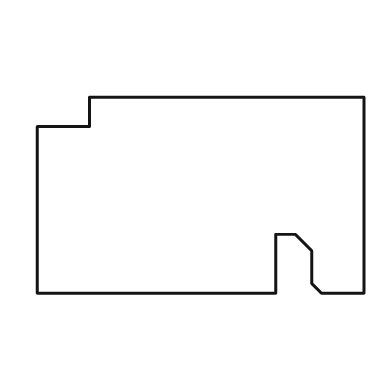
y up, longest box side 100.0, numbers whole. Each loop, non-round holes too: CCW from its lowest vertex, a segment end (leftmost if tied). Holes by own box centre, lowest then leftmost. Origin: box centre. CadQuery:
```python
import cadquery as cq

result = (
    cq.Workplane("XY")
    .moveTo(-50.0, -30.0)
    .lineTo(23.0, -30.0)
    .lineTo(23.0, -12.0)
    .lineTo(29.0, -12.0)
    .lineTo(34.0, -17.0)
    .lineTo(34.0, -27.0)
    .lineTo(37.0, -30.0)
    .lineTo(50.0, -30.0)
    .lineTo(50.0, 30.0)
    .lineTo(-34.0, 30.0)
    .lineTo(-34.0, 21.0)
    .lineTo(-50.0, 21.0)
    .close()
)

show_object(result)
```